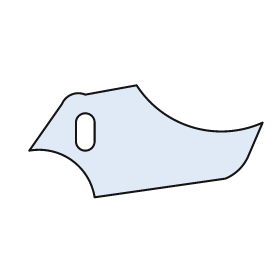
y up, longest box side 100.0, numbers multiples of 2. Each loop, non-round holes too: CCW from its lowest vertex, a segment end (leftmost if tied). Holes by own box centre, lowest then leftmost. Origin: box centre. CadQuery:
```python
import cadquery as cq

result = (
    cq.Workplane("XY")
    .moveTo(-22.0, -24.0)
    .lineTo(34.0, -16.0)
    .threePointArc((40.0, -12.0), (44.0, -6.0))
    .lineTo(50.0, 8.0)
    .threePointArc((20.0, 6.0), (-4.0, 24.0))
    .lineTo(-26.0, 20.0)
    .threePointArc((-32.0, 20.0), (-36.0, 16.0))
    .lineTo(-50.0, -4.0)
    .threePointArc((-32.0, -8.0), (-22.0, -24.0))
    .close()
    .moveTo(-30.0, 0.0)
    .threePointArc((-26.0, -4.0), (-22.0, 0.0))
    .lineTo(-22.0, 8.0)
    .threePointArc((-26.0, 12.0), (-30.0, 8.0))
    .close()
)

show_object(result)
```